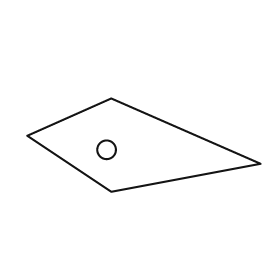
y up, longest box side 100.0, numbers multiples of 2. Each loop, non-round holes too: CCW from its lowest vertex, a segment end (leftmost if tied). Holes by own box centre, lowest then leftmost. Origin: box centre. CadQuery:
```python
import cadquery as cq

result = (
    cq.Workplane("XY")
    .moveTo(-14.0, -20.0)
    .lineTo(50.0, -8.0)
    .lineTo(-14.0, 20.0)
    .lineTo(-50.0, 4.0)
    .close()
    .moveTo(-16.0, -2.0)
    .circle(4.0)
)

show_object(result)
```